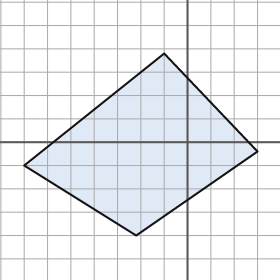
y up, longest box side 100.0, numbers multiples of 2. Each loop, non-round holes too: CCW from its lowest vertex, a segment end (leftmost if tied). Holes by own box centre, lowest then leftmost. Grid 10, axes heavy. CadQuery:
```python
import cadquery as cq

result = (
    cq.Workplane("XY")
    .moveTo(-22.0, -40.0)
    .lineTo(30.0, -4.0)
    .lineTo(-10.0, 38.0)
    .lineTo(-70.0, -10.0)
    .close()
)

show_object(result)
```